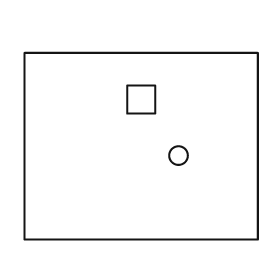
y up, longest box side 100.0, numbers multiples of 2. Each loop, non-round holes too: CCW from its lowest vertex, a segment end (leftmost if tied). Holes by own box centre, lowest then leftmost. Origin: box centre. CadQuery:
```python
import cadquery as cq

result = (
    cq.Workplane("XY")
    .moveTo(-50.0, -40.0)
    .lineTo(50.0, -40.0)
    .lineTo(50.0, 40.0)
    .lineTo(-50.0, 40.0)
    .close()
    .moveTo(16.0, -4.0)
    .circle(4.0)
    .moveTo(-6.0, 14.0)
    .lineTo(6.0, 14.0)
    .lineTo(6.0, 26.0)
    .lineTo(-6.0, 26.0)
    .close()
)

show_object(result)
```